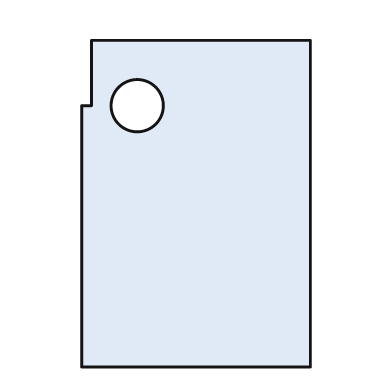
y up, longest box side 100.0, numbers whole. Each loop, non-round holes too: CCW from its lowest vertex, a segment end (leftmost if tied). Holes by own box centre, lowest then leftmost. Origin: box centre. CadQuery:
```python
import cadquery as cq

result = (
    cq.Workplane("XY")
    .moveTo(-35.0, -50.0)
    .lineTo(35.0, -50.0)
    .lineTo(35.0, 50.0)
    .lineTo(-32.0, 50.0)
    .lineTo(-32.0, 30.0)
    .lineTo(-35.0, 30.0)
    .close()
    .moveTo(-18.0, 30.0)
    .circle(8.0)
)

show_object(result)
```